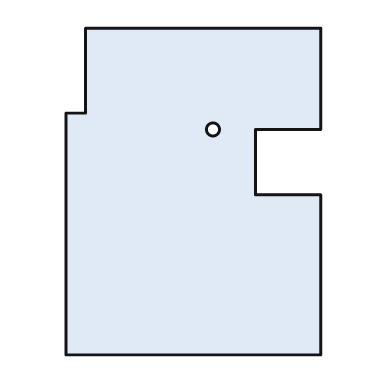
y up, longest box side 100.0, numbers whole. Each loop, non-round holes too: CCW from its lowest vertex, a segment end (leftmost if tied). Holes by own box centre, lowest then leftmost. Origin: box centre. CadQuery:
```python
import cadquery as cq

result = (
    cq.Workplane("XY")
    .moveTo(-39.0, -50.0)
    .lineTo(39.0, -50.0)
    .lineTo(39.0, -1.0)
    .lineTo(19.0, -1.0)
    .lineTo(19.0, 19.0)
    .lineTo(39.0, 19.0)
    .lineTo(39.0, 50.0)
    .lineTo(-33.0, 50.0)
    .lineTo(-33.0, 24.0)
    .lineTo(-39.0, 24.0)
    .close()
    .moveTo(6.0, 19.0)
    .circle(2.0)
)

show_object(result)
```